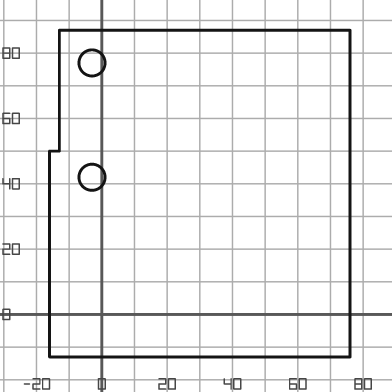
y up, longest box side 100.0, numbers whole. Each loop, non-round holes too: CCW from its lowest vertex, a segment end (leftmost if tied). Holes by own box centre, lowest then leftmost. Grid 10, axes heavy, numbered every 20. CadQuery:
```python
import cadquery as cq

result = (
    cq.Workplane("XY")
    .moveTo(-16.0, -13.0)
    .lineTo(76.0, -13.0)
    .lineTo(76.0, 87.0)
    .lineTo(-13.0, 87.0)
    .lineTo(-13.0, 50.0)
    .lineTo(-16.0, 50.0)
    .close()
    .moveTo(-3.0, 42.0)
    .circle(4.0)
    .moveTo(-3.0, 77.0)
    .circle(4.0)
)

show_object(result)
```